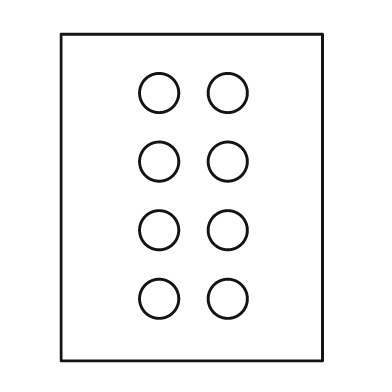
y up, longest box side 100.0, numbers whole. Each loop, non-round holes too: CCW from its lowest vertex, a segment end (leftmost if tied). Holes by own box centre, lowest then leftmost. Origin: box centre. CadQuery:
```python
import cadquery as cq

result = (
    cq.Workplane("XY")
    .moveTo(-40.0, -50.0)
    .lineTo(40.0, -50.0)
    .lineTo(40.0, 50.0)
    .lineTo(-40.0, 50.0)
    .close()
    .moveTo(-10.0, -31.0)
    .circle(6.0)
    .moveTo(11.0, -31.0)
    .circle(6.0)
    .moveTo(-10.0, -10.0)
    .circle(6.0)
    .moveTo(11.0, -10.0)
    .circle(6.0)
    .moveTo(-10.0, 11.0)
    .circle(6.0)
    .moveTo(11.0, 11.0)
    .circle(6.0)
    .moveTo(-10.0, 32.0)
    .circle(6.0)
    .moveTo(11.0, 32.0)
    .circle(6.0)
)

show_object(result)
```